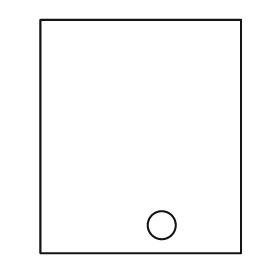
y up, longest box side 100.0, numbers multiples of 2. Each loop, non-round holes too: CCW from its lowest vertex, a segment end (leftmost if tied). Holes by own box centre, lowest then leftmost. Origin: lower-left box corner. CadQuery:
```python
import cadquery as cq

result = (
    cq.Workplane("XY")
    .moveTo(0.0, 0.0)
    .lineTo(86.0, 0.0)
    .lineTo(86.0, 100.0)
    .lineTo(0.0, 100.0)
    .close()
    .moveTo(52.0, 12.0)
    .circle(6.0)
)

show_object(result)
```